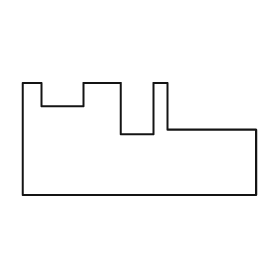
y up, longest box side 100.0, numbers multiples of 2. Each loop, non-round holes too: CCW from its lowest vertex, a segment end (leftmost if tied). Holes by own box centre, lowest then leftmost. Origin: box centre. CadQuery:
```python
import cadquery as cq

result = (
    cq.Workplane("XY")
    .moveTo(-50.0, -24.0)
    .lineTo(50.0, -24.0)
    .lineTo(50.0, 4.0)
    .lineTo(12.0, 4.0)
    .lineTo(12.0, 24.0)
    .lineTo(6.0, 24.0)
    .lineTo(6.0, 2.0)
    .lineTo(-8.0, 2.0)
    .lineTo(-8.0, 24.0)
    .lineTo(-24.0, 24.0)
    .lineTo(-24.0, 14.0)
    .lineTo(-42.0, 14.0)
    .lineTo(-42.0, 24.0)
    .lineTo(-50.0, 24.0)
    .close()
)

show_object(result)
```